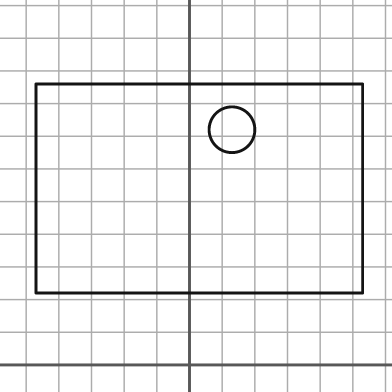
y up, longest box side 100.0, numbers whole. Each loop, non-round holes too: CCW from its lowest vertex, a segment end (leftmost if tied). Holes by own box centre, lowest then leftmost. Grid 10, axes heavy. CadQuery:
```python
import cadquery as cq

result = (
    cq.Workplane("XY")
    .moveTo(-47.0, 22.0)
    .lineTo(53.0, 22.0)
    .lineTo(53.0, 86.0)
    .lineTo(-47.0, 86.0)
    .close()
    .moveTo(13.0, 72.0)
    .circle(7.0)
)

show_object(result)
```